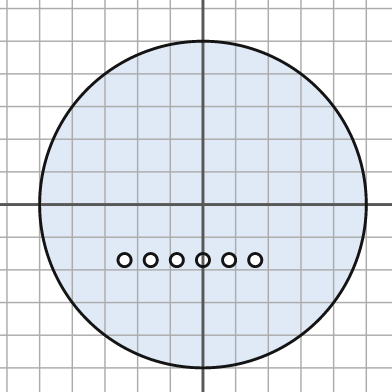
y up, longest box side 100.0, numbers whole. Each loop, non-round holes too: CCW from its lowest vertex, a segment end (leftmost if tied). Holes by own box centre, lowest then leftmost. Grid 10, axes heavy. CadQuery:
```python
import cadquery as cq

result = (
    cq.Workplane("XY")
    .moveTo(0.0, 0.0)
    .circle(50.0)
    .moveTo(-24.0, -17.0)
    .circle(2.0)
    .moveTo(-16.0, -17.0)
    .circle(2.0)
    .moveTo(-8.0, -17.0)
    .circle(2.0)
    .moveTo(0.0, -17.0)
    .circle(2.0)
    .moveTo(8.0, -17.0)
    .circle(2.0)
    .moveTo(16.0, -17.0)
    .circle(2.0)
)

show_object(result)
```